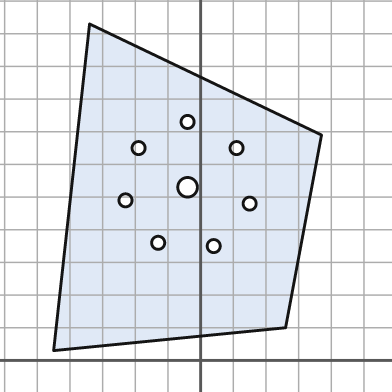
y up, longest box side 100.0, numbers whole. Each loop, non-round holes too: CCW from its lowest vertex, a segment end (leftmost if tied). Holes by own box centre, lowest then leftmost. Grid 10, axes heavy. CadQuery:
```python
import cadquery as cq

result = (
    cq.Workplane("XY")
    .moveTo(-45.0, 3.0)
    .lineTo(26.0, 10.0)
    .lineTo(37.0, 69.0)
    .lineTo(-34.0, 103.0)
    .close()
    .moveTo(4.0, 35.0)
    .circle(2.0)
    .moveTo(-13.0, 36.0)
    .circle(2.0)
    .moveTo(15.0, 48.0)
    .circle(2.0)
    .moveTo(-23.0, 49.0)
    .circle(2.0)
    .moveTo(-4.0, 53.0)
    .circle(3.0)
    .moveTo(-19.0, 65.0)
    .circle(2.0)
    .moveTo(11.0, 65.0)
    .circle(2.0)
    .moveTo(-4.0, 73.0)
    .circle(2.0)
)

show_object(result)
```